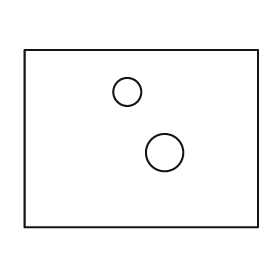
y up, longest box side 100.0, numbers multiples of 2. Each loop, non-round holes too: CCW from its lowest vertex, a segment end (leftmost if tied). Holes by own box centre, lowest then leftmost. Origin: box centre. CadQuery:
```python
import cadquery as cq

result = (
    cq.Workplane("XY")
    .moveTo(-50.0, -38.0)
    .lineTo(50.0, -38.0)
    .lineTo(50.0, 38.0)
    .lineTo(-50.0, 38.0)
    .close()
    .moveTo(10.0, -6.0)
    .circle(8.0)
    .moveTo(-6.0, 20.0)
    .circle(6.0)
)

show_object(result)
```